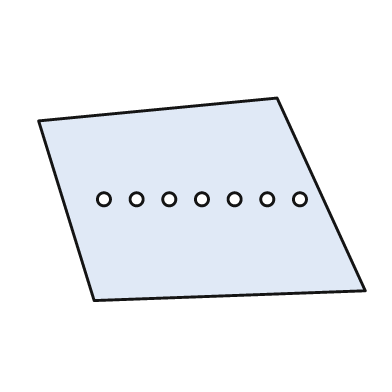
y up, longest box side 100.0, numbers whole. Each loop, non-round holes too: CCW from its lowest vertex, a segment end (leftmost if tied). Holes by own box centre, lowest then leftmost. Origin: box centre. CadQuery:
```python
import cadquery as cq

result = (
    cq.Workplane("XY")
    .moveTo(-33.0, -31.0)
    .lineTo(50.0, -28.0)
    .lineTo(23.0, 31.0)
    .lineTo(-50.0, 24.0)
    .close()
    .moveTo(-30.0, 0.0)
    .circle(2.0)
    .moveTo(-20.0, 0.0)
    .circle(2.0)
    .moveTo(-10.0, 0.0)
    .circle(2.0)
    .moveTo(0.0, 0.0)
    .circle(2.0)
    .moveTo(10.0, 0.0)
    .circle(2.0)
    .moveTo(20.0, 0.0)
    .circle(2.0)
    .moveTo(30.0, 0.0)
    .circle(2.0)
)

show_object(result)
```